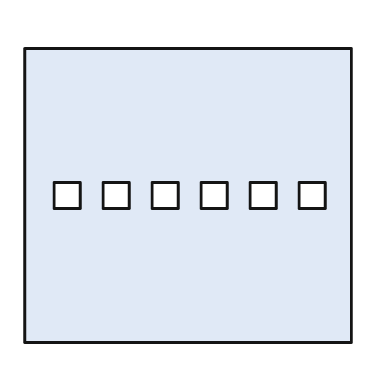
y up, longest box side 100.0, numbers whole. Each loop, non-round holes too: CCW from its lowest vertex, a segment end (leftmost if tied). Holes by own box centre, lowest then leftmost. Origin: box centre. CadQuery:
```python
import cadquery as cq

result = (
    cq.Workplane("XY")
    .moveTo(-50.0, -45.0)
    .lineTo(50.0, -45.0)
    .lineTo(50.0, 45.0)
    .lineTo(-50.0, 45.0)
    .close()
    .moveTo(-41.0, -4.0)
    .lineTo(-33.0, -4.0)
    .lineTo(-33.0, 4.0)
    .lineTo(-41.0, 4.0)
    .close()
    .moveTo(-26.0, -4.0)
    .lineTo(-18.0, -4.0)
    .lineTo(-18.0, 4.0)
    .lineTo(-26.0, 4.0)
    .close()
    .moveTo(-11.0, -4.0)
    .lineTo(-3.0, -4.0)
    .lineTo(-3.0, 4.0)
    .lineTo(-11.0, 4.0)
    .close()
    .moveTo(4.0, -4.0)
    .lineTo(12.0, -4.0)
    .lineTo(12.0, 4.0)
    .lineTo(4.0, 4.0)
    .close()
    .moveTo(19.0, -4.0)
    .lineTo(27.0, -4.0)
    .lineTo(27.0, 4.0)
    .lineTo(19.0, 4.0)
    .close()
    .moveTo(34.0, -4.0)
    .lineTo(42.0, -4.0)
    .lineTo(42.0, 4.0)
    .lineTo(34.0, 4.0)
    .close()
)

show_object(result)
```